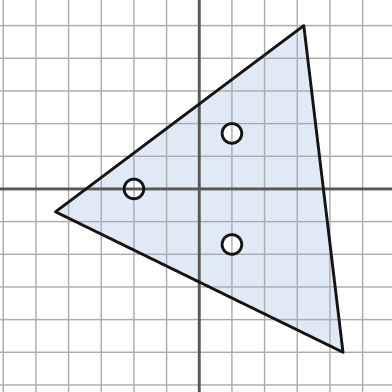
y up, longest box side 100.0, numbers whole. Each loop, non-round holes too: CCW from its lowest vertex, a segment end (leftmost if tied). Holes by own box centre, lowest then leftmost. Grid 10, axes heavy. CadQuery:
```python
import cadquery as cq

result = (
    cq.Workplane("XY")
    .moveTo(44.0, -50.0)
    .lineTo(32.0, 50.0)
    .lineTo(-44.0, -7.0)
    .close()
    .moveTo(10.0, -17.0)
    .circle(3.0)
    .moveTo(-20.0, 0.0)
    .circle(3.0)
    .moveTo(10.0, 17.0)
    .circle(3.0)
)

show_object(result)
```